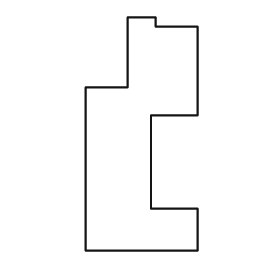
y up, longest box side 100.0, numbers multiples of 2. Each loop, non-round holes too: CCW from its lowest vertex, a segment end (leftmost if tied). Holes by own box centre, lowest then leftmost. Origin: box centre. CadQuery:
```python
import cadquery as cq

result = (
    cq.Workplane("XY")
    .moveTo(-24.0, -50.0)
    .lineTo(24.0, -50.0)
    .lineTo(24.0, -32.0)
    .lineTo(4.0, -32.0)
    .lineTo(4.0, 8.0)
    .lineTo(24.0, 8.0)
    .lineTo(24.0, 46.0)
    .lineTo(6.0, 46.0)
    .lineTo(6.0, 50.0)
    .lineTo(-6.0, 50.0)
    .lineTo(-6.0, 20.0)
    .lineTo(-24.0, 20.0)
    .close()
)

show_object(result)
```